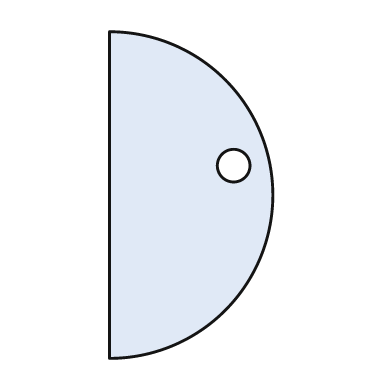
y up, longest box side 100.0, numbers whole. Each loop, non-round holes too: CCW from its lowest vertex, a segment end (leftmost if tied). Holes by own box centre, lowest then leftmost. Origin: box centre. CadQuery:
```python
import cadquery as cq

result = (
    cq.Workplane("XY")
    .moveTo(-25.0, -50.0)
    .threePointArc((25.0, 0.0), (-25.0, 50.0))
    .close()
    .moveTo(13.0, 9.0)
    .circle(5.0)
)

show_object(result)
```